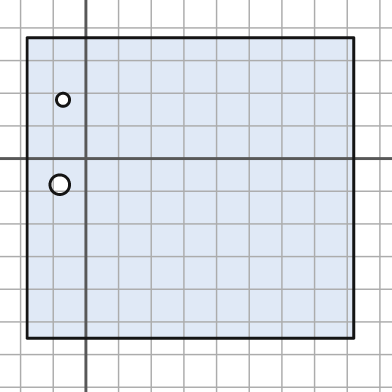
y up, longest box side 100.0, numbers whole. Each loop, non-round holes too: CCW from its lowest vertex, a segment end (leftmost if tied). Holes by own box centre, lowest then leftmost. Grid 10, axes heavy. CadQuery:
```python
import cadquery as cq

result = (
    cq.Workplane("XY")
    .moveTo(-18.0, -55.0)
    .lineTo(82.0, -55.0)
    .lineTo(82.0, 37.0)
    .lineTo(-18.0, 37.0)
    .close()
    .moveTo(-8.0, -8.0)
    .circle(3.0)
    .moveTo(-7.0, 18.0)
    .circle(2.0)
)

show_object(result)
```